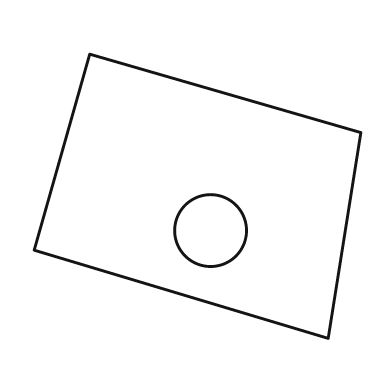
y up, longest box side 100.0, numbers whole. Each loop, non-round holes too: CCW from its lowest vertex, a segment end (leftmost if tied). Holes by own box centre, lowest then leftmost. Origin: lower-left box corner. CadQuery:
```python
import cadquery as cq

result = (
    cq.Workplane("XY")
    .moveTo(90.0, 0.0)
    .lineTo(100.0, 63.0)
    .lineTo(17.0, 87.0)
    .lineTo(0.0, 27.0)
    .close()
    .moveTo(54.0, 33.0)
    .circle(11.0)
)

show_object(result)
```